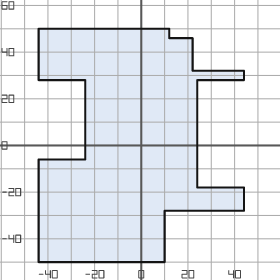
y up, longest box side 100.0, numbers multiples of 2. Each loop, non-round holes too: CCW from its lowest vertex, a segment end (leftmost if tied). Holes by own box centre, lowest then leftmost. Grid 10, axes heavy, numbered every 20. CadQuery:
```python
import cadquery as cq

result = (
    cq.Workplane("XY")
    .moveTo(-44.0, -50.0)
    .lineTo(10.0, -50.0)
    .lineTo(10.0, -28.0)
    .lineTo(44.0, -28.0)
    .lineTo(44.0, -18.0)
    .lineTo(24.0, -18.0)
    .lineTo(24.0, 28.0)
    .lineTo(44.0, 28.0)
    .lineTo(44.0, 32.0)
    .lineTo(22.0, 32.0)
    .lineTo(22.0, 46.0)
    .lineTo(12.0, 46.0)
    .lineTo(12.0, 50.0)
    .lineTo(-44.0, 50.0)
    .lineTo(-44.0, 28.0)
    .lineTo(-24.0, 28.0)
    .lineTo(-24.0, -6.0)
    .lineTo(-44.0, -6.0)
    .close()
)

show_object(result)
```